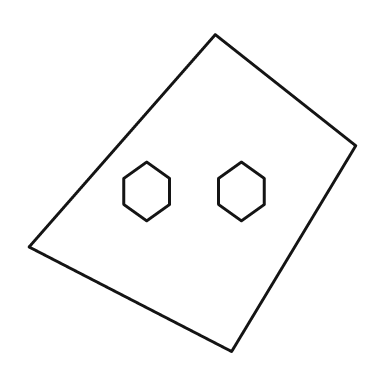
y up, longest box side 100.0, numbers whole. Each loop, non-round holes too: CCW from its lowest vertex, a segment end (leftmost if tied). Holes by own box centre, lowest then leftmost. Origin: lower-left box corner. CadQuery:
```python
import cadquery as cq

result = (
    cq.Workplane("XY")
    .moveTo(62.0, 0.0)
    .lineTo(100.0, 63.0)
    .lineTo(57.0, 97.0)
    .lineTo(0.0, 32.0)
    .close()
    .moveTo(36.0, 40.0)
    .lineTo(43.0, 45.0)
    .lineTo(43.0, 53.0)
    .lineTo(36.0, 58.0)
    .lineTo(29.0, 53.0)
    .lineTo(29.0, 45.0)
    .close()
    .moveTo(65.0, 40.0)
    .lineTo(72.0, 45.0)
    .lineTo(72.0, 53.0)
    .lineTo(65.0, 58.0)
    .lineTo(58.0, 53.0)
    .lineTo(58.0, 45.0)
    .close()
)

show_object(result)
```